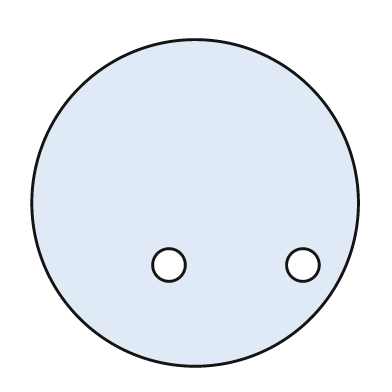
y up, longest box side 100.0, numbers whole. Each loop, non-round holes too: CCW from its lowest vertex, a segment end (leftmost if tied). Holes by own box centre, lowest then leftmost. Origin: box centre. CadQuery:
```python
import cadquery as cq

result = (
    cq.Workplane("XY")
    .moveTo(0.0, 0.0)
    .circle(50.0)
    .moveTo(-8.0, -19.0)
    .circle(5.0)
    .moveTo(33.0, -19.0)
    .circle(5.0)
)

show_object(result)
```